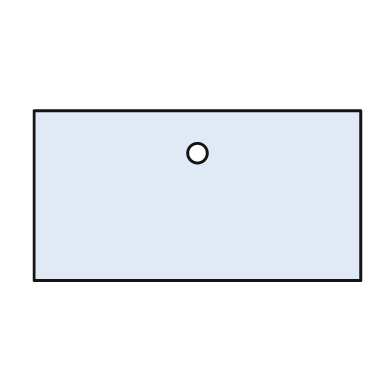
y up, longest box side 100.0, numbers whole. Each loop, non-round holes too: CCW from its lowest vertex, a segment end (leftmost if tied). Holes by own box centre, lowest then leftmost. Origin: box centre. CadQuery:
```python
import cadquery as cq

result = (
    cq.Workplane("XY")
    .moveTo(-50.0, -26.0)
    .lineTo(50.0, -26.0)
    .lineTo(50.0, 26.0)
    .lineTo(-50.0, 26.0)
    .close()
    .moveTo(0.0, 13.0)
    .circle(3.0)
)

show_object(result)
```